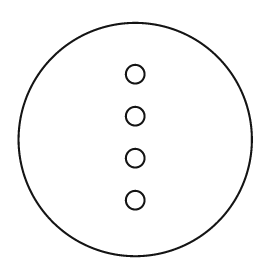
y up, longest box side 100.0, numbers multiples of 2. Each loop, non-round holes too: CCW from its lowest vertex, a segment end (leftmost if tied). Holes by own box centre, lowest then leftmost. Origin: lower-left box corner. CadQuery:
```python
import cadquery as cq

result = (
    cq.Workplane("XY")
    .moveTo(50.0, 50.0)
    .circle(50.0)
    .moveTo(50.0, 24.0)
    .circle(4.0)
    .moveTo(50.0, 42.0)
    .circle(4.0)
    .moveTo(50.0, 60.0)
    .circle(4.0)
    .moveTo(50.0, 78.0)
    .circle(4.0)
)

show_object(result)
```